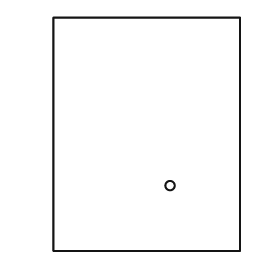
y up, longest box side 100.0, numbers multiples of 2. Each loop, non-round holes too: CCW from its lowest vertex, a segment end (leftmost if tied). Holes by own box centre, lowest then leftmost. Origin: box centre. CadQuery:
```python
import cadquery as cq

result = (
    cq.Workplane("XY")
    .moveTo(-40.0, -50.0)
    .lineTo(40.0, -50.0)
    .lineTo(40.0, 50.0)
    .lineTo(-40.0, 50.0)
    .close()
    .moveTo(10.0, -22.0)
    .circle(2.0)
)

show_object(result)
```